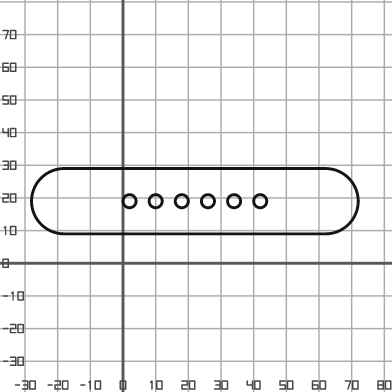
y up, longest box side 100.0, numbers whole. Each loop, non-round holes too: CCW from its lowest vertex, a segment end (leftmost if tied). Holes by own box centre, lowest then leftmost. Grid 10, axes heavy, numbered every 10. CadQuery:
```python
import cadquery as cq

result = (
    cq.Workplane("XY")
    .moveTo(-18.0, 9.0)
    .lineTo(62.0, 9.0)
    .threePointArc((72.0, 19.0), (62.0, 29.0))
    .lineTo(-18.0, 29.0)
    .threePointArc((-28.0, 19.0), (-18.0, 9.0))
    .close()
    .moveTo(2.0, 19.0)
    .circle(2.0)
    .moveTo(10.0, 19.0)
    .circle(2.0)
    .moveTo(18.0, 19.0)
    .circle(2.0)
    .moveTo(26.0, 19.0)
    .circle(2.0)
    .moveTo(34.0, 19.0)
    .circle(2.0)
    .moveTo(42.0, 19.0)
    .circle(2.0)
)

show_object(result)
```